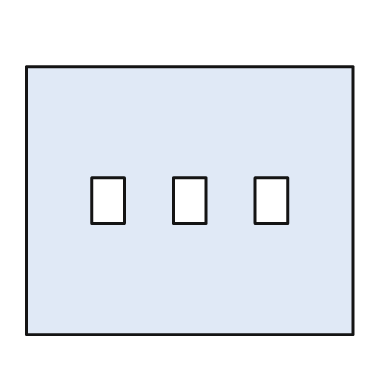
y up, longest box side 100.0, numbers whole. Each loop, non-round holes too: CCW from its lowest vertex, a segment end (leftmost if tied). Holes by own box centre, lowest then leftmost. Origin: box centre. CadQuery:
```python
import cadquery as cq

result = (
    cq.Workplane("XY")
    .moveTo(-50.0, -41.0)
    .lineTo(50.0, -41.0)
    .lineTo(50.0, 41.0)
    .lineTo(-50.0, 41.0)
    .close()
    .moveTo(-30.0, -7.0)
    .lineTo(-20.0, -7.0)
    .lineTo(-20.0, 7.0)
    .lineTo(-30.0, 7.0)
    .close()
    .moveTo(-5.0, -7.0)
    .lineTo(5.0, -7.0)
    .lineTo(5.0, 7.0)
    .lineTo(-5.0, 7.0)
    .close()
    .moveTo(20.0, -7.0)
    .lineTo(30.0, -7.0)
    .lineTo(30.0, 7.0)
    .lineTo(20.0, 7.0)
    .close()
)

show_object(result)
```